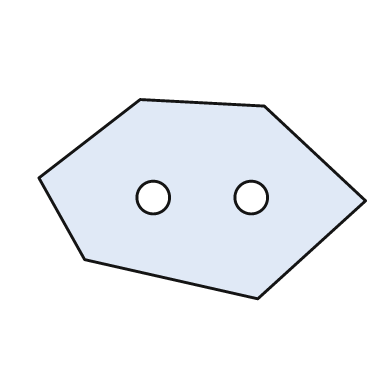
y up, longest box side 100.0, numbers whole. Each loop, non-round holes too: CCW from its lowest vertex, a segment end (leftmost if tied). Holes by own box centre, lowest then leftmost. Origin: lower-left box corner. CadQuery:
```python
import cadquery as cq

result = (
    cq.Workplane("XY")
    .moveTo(67.0, 0.0)
    .lineTo(100.0, 30.0)
    .lineTo(69.0, 59.0)
    .lineTo(31.0, 61.0)
    .lineTo(0.0, 37.0)
    .lineTo(14.0, 12.0)
    .close()
    .moveTo(35.0, 31.0)
    .circle(5.0)
    .moveTo(65.0, 31.0)
    .circle(5.0)
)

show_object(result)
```